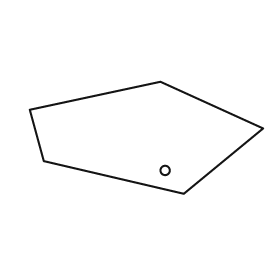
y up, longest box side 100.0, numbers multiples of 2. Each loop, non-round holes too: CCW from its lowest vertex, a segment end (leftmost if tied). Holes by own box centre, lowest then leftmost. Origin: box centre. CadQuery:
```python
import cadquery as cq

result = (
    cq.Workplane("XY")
    .moveTo(16.0, -24.0)
    .lineTo(50.0, 4.0)
    .lineTo(6.0, 24.0)
    .lineTo(-50.0, 12.0)
    .lineTo(-44.0, -10.0)
    .close()
    .moveTo(8.0, -14.0)
    .circle(2.0)
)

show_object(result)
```